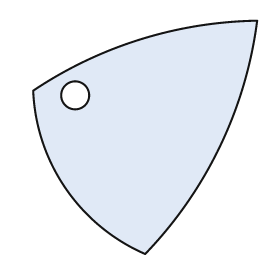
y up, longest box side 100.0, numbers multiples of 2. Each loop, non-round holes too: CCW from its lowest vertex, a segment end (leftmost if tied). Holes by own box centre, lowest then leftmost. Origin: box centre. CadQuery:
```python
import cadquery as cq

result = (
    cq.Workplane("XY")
    .moveTo(0.0, -50.0)
    .threePointArc((32.0, -4.0), (48.0, 50.0))
    .threePointArc((-2.0, 42.0), (-48.0, 20.0))
    .threePointArc((-34.0, -22.0), (0.0, -50.0))
    .close()
    .moveTo(-30.0, 18.0)
    .circle(6.0)
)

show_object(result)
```